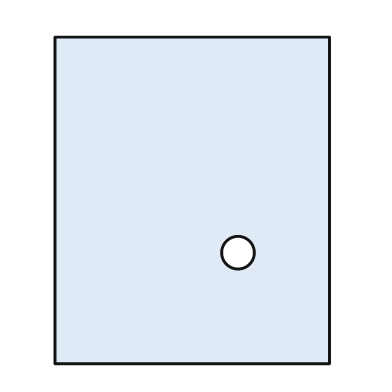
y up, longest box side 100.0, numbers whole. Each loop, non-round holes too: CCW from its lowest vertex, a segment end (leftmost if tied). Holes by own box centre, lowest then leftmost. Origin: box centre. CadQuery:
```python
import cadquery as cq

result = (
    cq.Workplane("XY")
    .moveTo(-42.0, -50.0)
    .lineTo(42.0, -50.0)
    .lineTo(42.0, 50.0)
    .lineTo(-42.0, 50.0)
    .close()
    .moveTo(14.0, -16.0)
    .circle(5.0)
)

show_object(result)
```